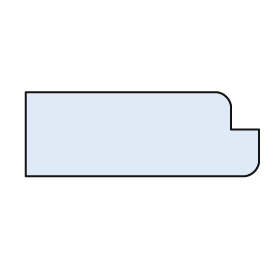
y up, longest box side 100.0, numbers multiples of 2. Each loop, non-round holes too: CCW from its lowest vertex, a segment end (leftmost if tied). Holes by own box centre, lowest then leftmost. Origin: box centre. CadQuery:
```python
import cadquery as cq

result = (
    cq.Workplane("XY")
    .moveTo(-50.0, -18.0)
    .lineTo(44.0, -18.0)
    .threePointArc((48.0, -16.0), (50.0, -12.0))
    .lineTo(50.0, 2.0)
    .lineTo(38.0, 2.0)
    .lineTo(38.0, 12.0)
    .threePointArc((36.0, 16.0), (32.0, 18.0))
    .lineTo(-50.0, 18.0)
    .close()
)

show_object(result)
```